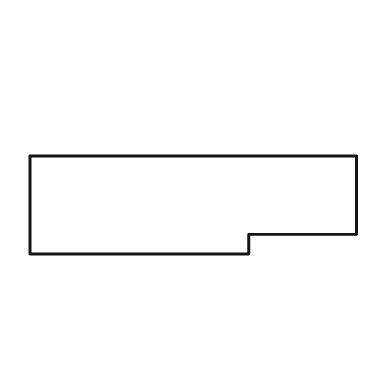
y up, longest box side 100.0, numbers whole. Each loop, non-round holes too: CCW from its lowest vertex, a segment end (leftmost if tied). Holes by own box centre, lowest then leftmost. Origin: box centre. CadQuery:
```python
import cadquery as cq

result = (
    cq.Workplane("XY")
    .moveTo(-50.0, -15.0)
    .lineTo(17.0, -15.0)
    .lineTo(17.0, -9.0)
    .lineTo(50.0, -9.0)
    .lineTo(50.0, 15.0)
    .lineTo(-50.0, 15.0)
    .close()
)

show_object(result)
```